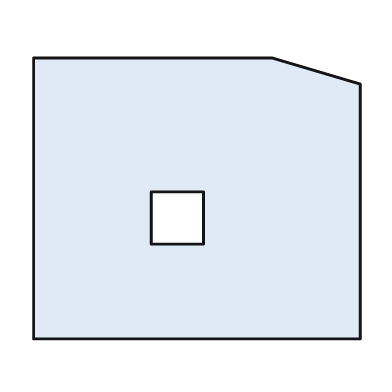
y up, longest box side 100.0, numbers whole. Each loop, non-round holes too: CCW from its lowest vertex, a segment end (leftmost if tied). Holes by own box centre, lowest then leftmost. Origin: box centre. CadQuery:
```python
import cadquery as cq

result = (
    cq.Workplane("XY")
    .moveTo(-50.0, -43.0)
    .lineTo(50.0, -43.0)
    .lineTo(50.0, 35.0)
    .lineTo(23.0, 43.0)
    .lineTo(-50.0, 43.0)
    .close()
    .moveTo(-14.0, -14.0)
    .lineTo(2.0, -14.0)
    .lineTo(2.0, 2.0)
    .lineTo(-14.0, 2.0)
    .close()
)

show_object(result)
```